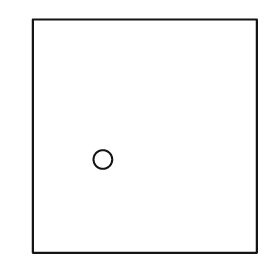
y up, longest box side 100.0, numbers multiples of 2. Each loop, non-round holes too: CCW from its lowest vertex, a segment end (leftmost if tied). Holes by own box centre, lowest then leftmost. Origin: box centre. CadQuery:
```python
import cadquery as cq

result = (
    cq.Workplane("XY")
    .moveTo(-48.0, -50.0)
    .lineTo(48.0, -50.0)
    .lineTo(48.0, 50.0)
    .lineTo(-48.0, 50.0)
    .close()
    .moveTo(-18.0, -10.0)
    .circle(4.0)
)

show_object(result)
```